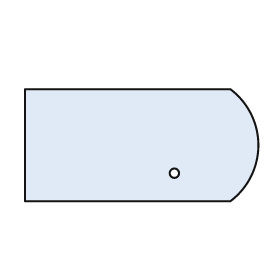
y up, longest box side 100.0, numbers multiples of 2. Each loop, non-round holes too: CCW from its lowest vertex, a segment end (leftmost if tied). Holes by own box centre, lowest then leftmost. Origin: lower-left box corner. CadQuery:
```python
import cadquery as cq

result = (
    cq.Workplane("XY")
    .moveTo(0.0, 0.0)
    .lineTo(88.0, 0.0)
    .threePointArc((100.0, 24.0), (88.0, 48.0))
    .lineTo(0.0, 48.0)
    .close()
    .moveTo(64.0, 12.0)
    .circle(2.0)
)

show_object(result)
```